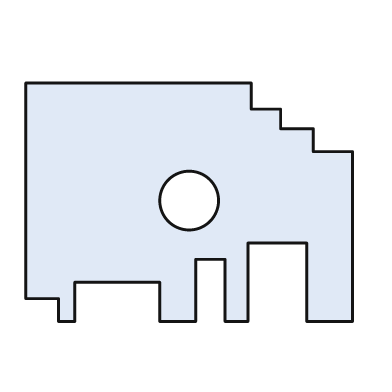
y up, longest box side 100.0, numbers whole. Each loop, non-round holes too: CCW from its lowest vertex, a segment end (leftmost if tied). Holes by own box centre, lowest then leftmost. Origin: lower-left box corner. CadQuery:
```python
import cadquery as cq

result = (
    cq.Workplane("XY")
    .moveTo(10.0, 0.0)
    .lineTo(15.0, 0.0)
    .lineTo(15.0, 12.0)
    .lineTo(41.0, 12.0)
    .lineTo(41.0, 0.0)
    .lineTo(52.0, 0.0)
    .lineTo(52.0, 19.0)
    .lineTo(61.0, 19.0)
    .lineTo(61.0, 0.0)
    .lineTo(68.0, 0.0)
    .lineTo(68.0, 24.0)
    .lineTo(86.0, 24.0)
    .lineTo(86.0, 0.0)
    .lineTo(100.0, 0.0)
    .lineTo(100.0, 52.0)
    .lineTo(88.0, 52.0)
    .lineTo(88.0, 59.0)
    .lineTo(78.0, 59.0)
    .lineTo(78.0, 65.0)
    .lineTo(69.0, 65.0)
    .lineTo(69.0, 73.0)
    .lineTo(0.0, 73.0)
    .lineTo(0.0, 7.0)
    .lineTo(10.0, 7.0)
    .close()
    .moveTo(50.0, 37.0)
    .circle(9.0)
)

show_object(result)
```